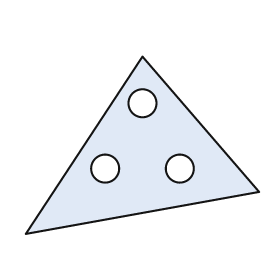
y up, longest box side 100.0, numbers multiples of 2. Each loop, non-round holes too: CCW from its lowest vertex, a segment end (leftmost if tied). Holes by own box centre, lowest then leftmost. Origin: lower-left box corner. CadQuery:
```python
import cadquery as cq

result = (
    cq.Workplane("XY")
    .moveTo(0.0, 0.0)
    .lineTo(100.0, 18.0)
    .lineTo(50.0, 76.0)
    .close()
    .moveTo(34.0, 28.0)
    .circle(6.0)
    .moveTo(66.0, 28.0)
    .circle(6.0)
    .moveTo(50.0, 56.0)
    .circle(6.0)
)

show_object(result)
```